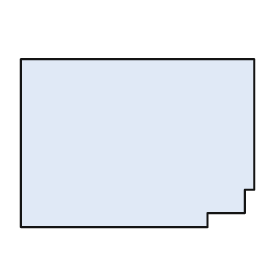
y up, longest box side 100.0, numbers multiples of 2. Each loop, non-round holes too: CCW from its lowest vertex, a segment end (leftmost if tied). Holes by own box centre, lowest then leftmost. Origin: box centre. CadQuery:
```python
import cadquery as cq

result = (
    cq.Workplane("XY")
    .moveTo(-50.0, -36.0)
    .lineTo(30.0, -36.0)
    .lineTo(30.0, -30.0)
    .lineTo(46.0, -30.0)
    .lineTo(46.0, -20.0)
    .lineTo(50.0, -20.0)
    .lineTo(50.0, 36.0)
    .lineTo(-50.0, 36.0)
    .close()
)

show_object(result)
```